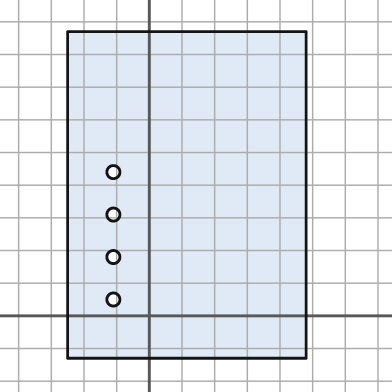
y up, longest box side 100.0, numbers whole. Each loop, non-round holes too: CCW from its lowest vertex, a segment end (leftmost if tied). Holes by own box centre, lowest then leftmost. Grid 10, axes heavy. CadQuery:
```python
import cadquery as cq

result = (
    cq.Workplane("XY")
    .moveTo(-25.0, -13.0)
    .lineTo(48.0, -13.0)
    .lineTo(48.0, 87.0)
    .lineTo(-25.0, 87.0)
    .close()
    .moveTo(-11.0, 5.0)
    .circle(2.0)
    .moveTo(-11.0, 18.0)
    .circle(2.0)
    .moveTo(-11.0, 31.0)
    .circle(2.0)
    .moveTo(-11.0, 44.0)
    .circle(2.0)
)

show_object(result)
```